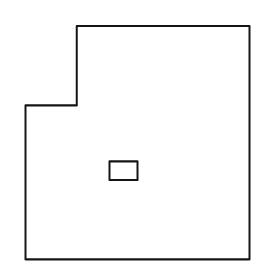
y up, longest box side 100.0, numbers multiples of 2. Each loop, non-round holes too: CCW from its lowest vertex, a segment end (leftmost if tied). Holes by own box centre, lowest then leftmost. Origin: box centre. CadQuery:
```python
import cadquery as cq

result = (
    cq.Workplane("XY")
    .moveTo(-48.0, -50.0)
    .lineTo(48.0, -50.0)
    .lineTo(48.0, 50.0)
    .lineTo(-26.0, 50.0)
    .lineTo(-26.0, 16.0)
    .lineTo(-48.0, 16.0)
    .close()
    .moveTo(-12.0, -16.0)
    .lineTo(0.0, -16.0)
    .lineTo(0.0, -8.0)
    .lineTo(-12.0, -8.0)
    .close()
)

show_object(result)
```